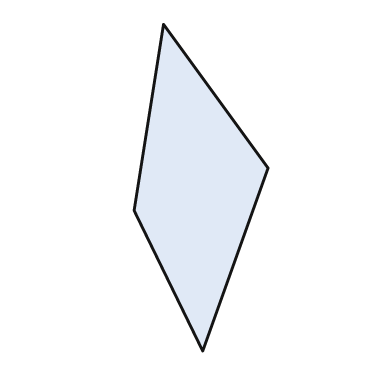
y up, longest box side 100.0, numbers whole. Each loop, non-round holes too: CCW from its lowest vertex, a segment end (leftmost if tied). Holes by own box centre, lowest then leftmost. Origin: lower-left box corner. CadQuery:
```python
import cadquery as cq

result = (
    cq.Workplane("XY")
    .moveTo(21.0, 0.0)
    .lineTo(41.0, 56.0)
    .lineTo(9.0, 100.0)
    .lineTo(0.0, 43.0)
    .close()
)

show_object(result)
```